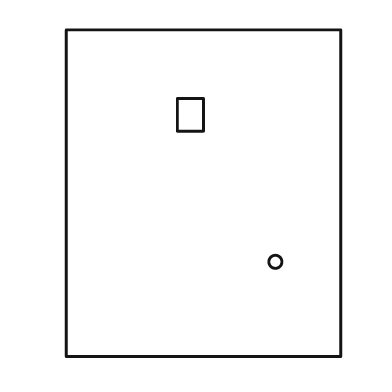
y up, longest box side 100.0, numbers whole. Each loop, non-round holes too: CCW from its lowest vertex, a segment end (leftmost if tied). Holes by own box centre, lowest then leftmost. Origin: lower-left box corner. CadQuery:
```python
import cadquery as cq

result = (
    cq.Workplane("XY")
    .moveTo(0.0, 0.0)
    .lineTo(84.0, 0.0)
    .lineTo(84.0, 100.0)
    .lineTo(0.0, 100.0)
    .close()
    .moveTo(64.0, 29.0)
    .circle(2.0)
    .moveTo(34.0, 69.0)
    .lineTo(42.0, 69.0)
    .lineTo(42.0, 79.0)
    .lineTo(34.0, 79.0)
    .close()
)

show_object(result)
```